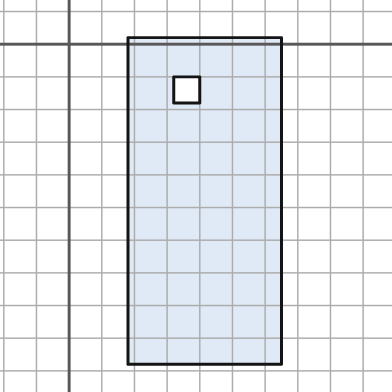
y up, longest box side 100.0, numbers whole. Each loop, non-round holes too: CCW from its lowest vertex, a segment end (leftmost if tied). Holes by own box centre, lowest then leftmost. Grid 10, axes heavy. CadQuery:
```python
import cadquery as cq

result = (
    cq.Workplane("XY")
    .moveTo(18.0, -98.0)
    .lineTo(65.0, -98.0)
    .lineTo(65.0, 2.0)
    .lineTo(18.0, 2.0)
    .close()
    .moveTo(32.0, -18.0)
    .lineTo(40.0, -18.0)
    .lineTo(40.0, -10.0)
    .lineTo(32.0, -10.0)
    .close()
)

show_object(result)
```